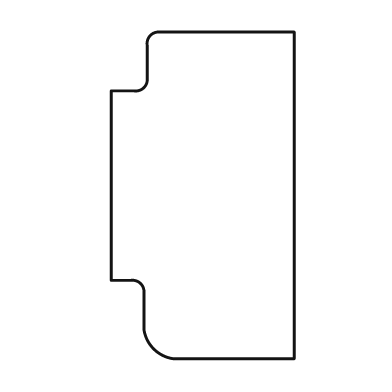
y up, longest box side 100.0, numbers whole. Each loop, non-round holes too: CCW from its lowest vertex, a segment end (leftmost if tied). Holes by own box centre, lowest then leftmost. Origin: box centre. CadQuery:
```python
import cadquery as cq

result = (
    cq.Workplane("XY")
    .moveTo(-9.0, -50.0)
    .lineTo(28.0, -50.0)
    .lineTo(28.0, 50.0)
    .lineTo(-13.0, 50.0)
    .threePointArc((-16.0, 49.0), (-17.0, 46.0))
    .lineTo(-17.0, 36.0)
    .threePointArc((-18.0, 33.0), (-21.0, 32.0))
    .lineTo(-28.0, 32.0)
    .lineTo(-28.0, -26.0)
    .lineTo(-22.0, -26.0)
    .threePointArc((-19.0, -27.0), (-18.0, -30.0))
    .lineTo(-18.0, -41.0)
    .threePointArc((-15.0, -47.0), (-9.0, -50.0))
    .close()
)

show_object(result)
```